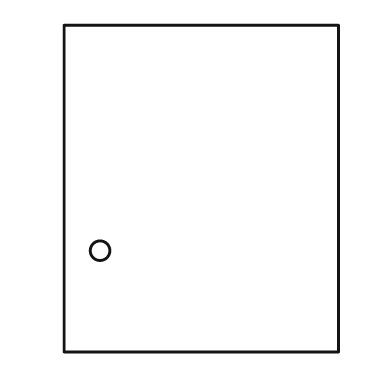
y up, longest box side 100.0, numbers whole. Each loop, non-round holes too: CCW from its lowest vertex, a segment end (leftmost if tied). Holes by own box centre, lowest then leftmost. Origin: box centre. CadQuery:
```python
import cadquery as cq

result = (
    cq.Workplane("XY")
    .moveTo(-42.0, -50.0)
    .lineTo(42.0, -50.0)
    .lineTo(42.0, 50.0)
    .lineTo(-42.0, 50.0)
    .close()
    .moveTo(-31.0, -19.0)
    .circle(3.0)
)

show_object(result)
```